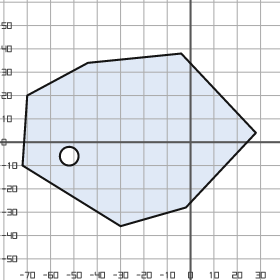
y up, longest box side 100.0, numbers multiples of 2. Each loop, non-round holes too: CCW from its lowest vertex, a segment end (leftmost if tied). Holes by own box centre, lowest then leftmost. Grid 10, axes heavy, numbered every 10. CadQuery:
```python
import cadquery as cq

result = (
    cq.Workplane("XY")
    .moveTo(-30.0, -36.0)
    .lineTo(-2.0, -28.0)
    .lineTo(28.0, 4.0)
    .lineTo(-4.0, 38.0)
    .lineTo(-44.0, 34.0)
    .lineTo(-70.0, 20.0)
    .lineTo(-72.0, -10.0)
    .close()
    .moveTo(-52.0, -6.0)
    .circle(4.0)
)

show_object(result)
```